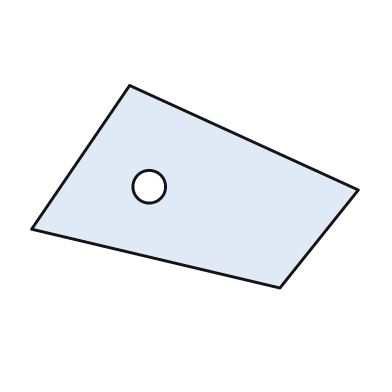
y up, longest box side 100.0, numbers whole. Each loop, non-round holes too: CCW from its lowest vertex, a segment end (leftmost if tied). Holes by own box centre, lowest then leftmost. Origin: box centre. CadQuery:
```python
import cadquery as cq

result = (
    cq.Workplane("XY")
    .moveTo(26.0, -31.0)
    .lineTo(50.0, -1.0)
    .lineTo(-20.0, 31.0)
    .lineTo(-50.0, -13.0)
    .close()
    .moveTo(-14.0, 0.0)
    .circle(5.0)
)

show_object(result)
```